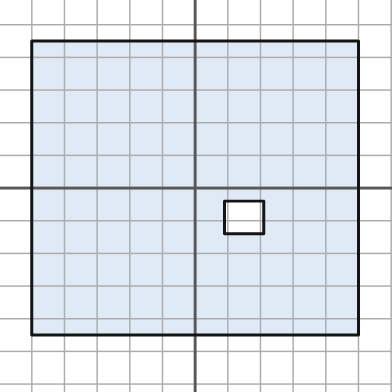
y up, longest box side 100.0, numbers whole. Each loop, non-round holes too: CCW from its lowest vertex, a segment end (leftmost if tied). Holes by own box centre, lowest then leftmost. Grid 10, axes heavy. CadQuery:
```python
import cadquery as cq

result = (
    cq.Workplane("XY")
    .moveTo(-50.0, -45.0)
    .lineTo(50.0, -45.0)
    .lineTo(50.0, 45.0)
    .lineTo(-50.0, 45.0)
    .close()
    .moveTo(9.0, -14.0)
    .lineTo(21.0, -14.0)
    .lineTo(21.0, -4.0)
    .lineTo(9.0, -4.0)
    .close()
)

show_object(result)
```